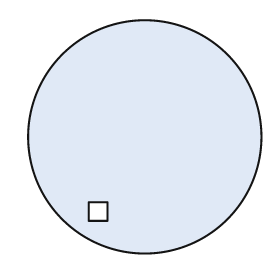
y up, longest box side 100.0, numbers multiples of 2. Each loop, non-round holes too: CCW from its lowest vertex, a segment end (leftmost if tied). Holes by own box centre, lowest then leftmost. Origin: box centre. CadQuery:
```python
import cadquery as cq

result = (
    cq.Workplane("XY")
    .moveTo(0.0, 0.0)
    .circle(50.0)
    .moveTo(-24.0, -36.0)
    .lineTo(-16.0, -36.0)
    .lineTo(-16.0, -28.0)
    .lineTo(-24.0, -28.0)
    .close()
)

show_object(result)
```